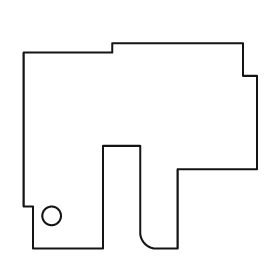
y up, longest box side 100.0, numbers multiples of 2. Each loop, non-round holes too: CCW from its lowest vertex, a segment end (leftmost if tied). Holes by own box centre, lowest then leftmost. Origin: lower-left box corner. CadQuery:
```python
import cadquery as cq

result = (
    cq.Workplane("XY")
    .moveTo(4.0, 0.0)
    .lineTo(34.0, 0.0)
    .lineTo(34.0, 44.0)
    .lineTo(50.0, 44.0)
    .lineTo(50.0, 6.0)
    .threePointArc((52.0, 2.0), (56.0, 0.0))
    .lineTo(66.0, 0.0)
    .lineTo(66.0, 34.0)
    .lineTo(100.0, 34.0)
    .lineTo(100.0, 74.0)
    .lineTo(94.0, 74.0)
    .lineTo(94.0, 88.0)
    .lineTo(38.0, 88.0)
    .lineTo(38.0, 84.0)
    .lineTo(0.0, 84.0)
    .lineTo(0.0, 18.0)
    .lineTo(4.0, 18.0)
    .close()
    .moveTo(12.0, 14.0)
    .circle(4.0)
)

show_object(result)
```